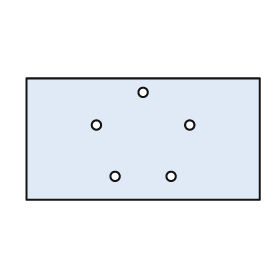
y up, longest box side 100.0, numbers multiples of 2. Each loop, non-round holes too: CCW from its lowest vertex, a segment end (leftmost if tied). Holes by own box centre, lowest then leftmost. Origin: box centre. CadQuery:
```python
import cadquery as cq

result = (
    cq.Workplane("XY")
    .moveTo(-50.0, -26.0)
    .lineTo(50.0, -26.0)
    .lineTo(50.0, 26.0)
    .lineTo(-50.0, 26.0)
    .close()
    .moveTo(-12.0, -16.0)
    .circle(2.0)
    .moveTo(12.0, -16.0)
    .circle(2.0)
    .moveTo(-20.0, 6.0)
    .circle(2.0)
    .moveTo(20.0, 6.0)
    .circle(2.0)
    .moveTo(0.0, 20.0)
    .circle(2.0)
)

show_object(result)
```